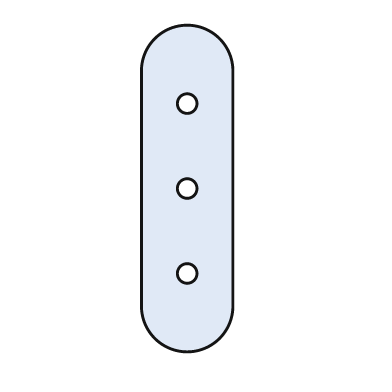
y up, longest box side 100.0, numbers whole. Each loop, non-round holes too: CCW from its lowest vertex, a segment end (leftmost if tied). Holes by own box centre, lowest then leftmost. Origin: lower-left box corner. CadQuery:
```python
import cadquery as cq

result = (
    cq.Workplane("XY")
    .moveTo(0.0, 14.0)
    .threePointArc((14.0, 0.0), (28.0, 14.0))
    .lineTo(28.0, 86.0)
    .threePointArc((14.0, 100.0), (0.0, 86.0))
    .close()
    .moveTo(14.0, 24.0)
    .circle(3.0)
    .moveTo(14.0, 50.0)
    .circle(3.0)
    .moveTo(14.0, 76.0)
    .circle(3.0)
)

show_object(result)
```